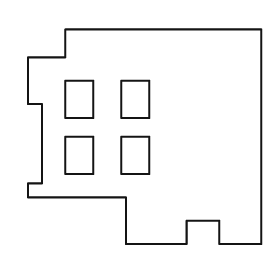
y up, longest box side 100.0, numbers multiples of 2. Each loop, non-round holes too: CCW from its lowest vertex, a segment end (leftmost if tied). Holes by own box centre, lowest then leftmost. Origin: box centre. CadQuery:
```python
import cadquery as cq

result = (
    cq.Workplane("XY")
    .moveTo(-8.0, -46.0)
    .lineTo(18.0, -46.0)
    .lineTo(18.0, -36.0)
    .lineTo(32.0, -36.0)
    .lineTo(32.0, -46.0)
    .lineTo(50.0, -46.0)
    .lineTo(50.0, 46.0)
    .lineTo(-34.0, 46.0)
    .lineTo(-34.0, 34.0)
    .lineTo(-50.0, 34.0)
    .lineTo(-50.0, 14.0)
    .lineTo(-44.0, 14.0)
    .lineTo(-44.0, -20.0)
    .lineTo(-50.0, -20.0)
    .lineTo(-50.0, -26.0)
    .lineTo(-8.0, -26.0)
    .close()
    .moveTo(-34.0, -16.0)
    .lineTo(-22.0, -16.0)
    .lineTo(-22.0, 0.0)
    .lineTo(-34.0, 0.0)
    .close()
    .moveTo(-10.0, -16.0)
    .lineTo(2.0, -16.0)
    .lineTo(2.0, 0.0)
    .lineTo(-10.0, 0.0)
    .close()
    .moveTo(-34.0, 8.0)
    .lineTo(-22.0, 8.0)
    .lineTo(-22.0, 24.0)
    .lineTo(-34.0, 24.0)
    .close()
    .moveTo(-10.0, 8.0)
    .lineTo(2.0, 8.0)
    .lineTo(2.0, 24.0)
    .lineTo(-10.0, 24.0)
    .close()
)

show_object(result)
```